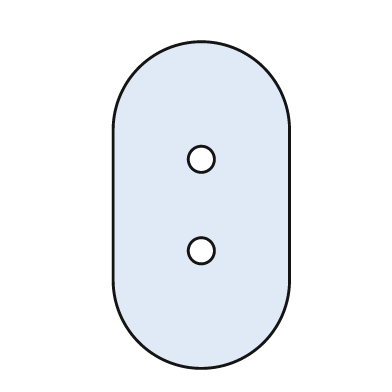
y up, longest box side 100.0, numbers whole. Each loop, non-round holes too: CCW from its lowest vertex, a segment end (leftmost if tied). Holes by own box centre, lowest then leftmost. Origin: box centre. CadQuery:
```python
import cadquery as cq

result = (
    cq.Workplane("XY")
    .moveTo(-27.0, -23.0)
    .threePointArc((0.0, -50.0), (27.0, -23.0))
    .lineTo(27.0, 23.0)
    .threePointArc((0.0, 50.0), (-27.0, 23.0))
    .close()
    .moveTo(0.0, -14.0)
    .circle(4.0)
    .moveTo(0.0, 14.0)
    .circle(4.0)
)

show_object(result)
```